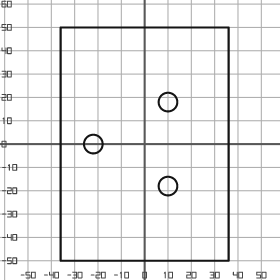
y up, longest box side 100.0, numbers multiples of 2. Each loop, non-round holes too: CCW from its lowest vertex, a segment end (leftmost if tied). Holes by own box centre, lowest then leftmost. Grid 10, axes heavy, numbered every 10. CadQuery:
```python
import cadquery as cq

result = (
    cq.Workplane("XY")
    .moveTo(-36.0, -50.0)
    .lineTo(36.0, -50.0)
    .lineTo(36.0, 50.0)
    .lineTo(-36.0, 50.0)
    .close()
    .moveTo(10.0, -18.0)
    .circle(4.0)
    .moveTo(-22.0, 0.0)
    .circle(4.0)
    .moveTo(10.0, 18.0)
    .circle(4.0)
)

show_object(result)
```